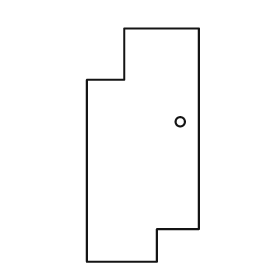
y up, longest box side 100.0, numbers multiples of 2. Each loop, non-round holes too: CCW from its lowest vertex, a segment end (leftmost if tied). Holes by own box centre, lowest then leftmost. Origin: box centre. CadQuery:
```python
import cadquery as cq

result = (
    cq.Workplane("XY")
    .moveTo(-24.0, -50.0)
    .lineTo(6.0, -50.0)
    .lineTo(6.0, -36.0)
    .lineTo(24.0, -36.0)
    .lineTo(24.0, 50.0)
    .lineTo(-8.0, 50.0)
    .lineTo(-8.0, 28.0)
    .lineTo(-24.0, 28.0)
    .close()
    .moveTo(16.0, 10.0)
    .circle(2.0)
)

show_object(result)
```